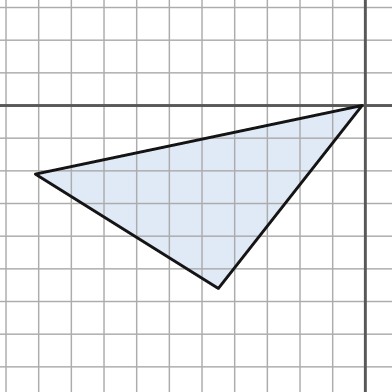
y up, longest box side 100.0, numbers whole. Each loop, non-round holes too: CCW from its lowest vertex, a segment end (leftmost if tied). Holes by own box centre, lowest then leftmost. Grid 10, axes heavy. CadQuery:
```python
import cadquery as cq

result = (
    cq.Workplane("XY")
    .moveTo(-45.0, -56.0)
    .lineTo(-1.0, 0.0)
    .lineTo(-101.0, -21.0)
    .close()
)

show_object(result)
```